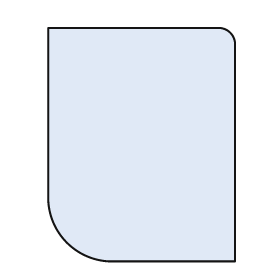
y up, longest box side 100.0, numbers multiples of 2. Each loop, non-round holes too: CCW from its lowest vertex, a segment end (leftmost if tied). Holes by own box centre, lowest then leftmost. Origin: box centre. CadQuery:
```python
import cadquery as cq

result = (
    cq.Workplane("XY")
    .moveTo(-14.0, -50.0)
    .lineTo(40.0, -50.0)
    .lineTo(40.0, 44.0)
    .threePointArc((38.0, 48.0), (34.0, 50.0))
    .lineTo(-40.0, 50.0)
    .lineTo(-40.0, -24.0)
    .threePointArc((-32.0, -42.0), (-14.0, -50.0))
    .close()
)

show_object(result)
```